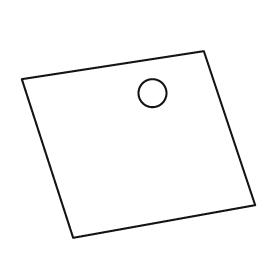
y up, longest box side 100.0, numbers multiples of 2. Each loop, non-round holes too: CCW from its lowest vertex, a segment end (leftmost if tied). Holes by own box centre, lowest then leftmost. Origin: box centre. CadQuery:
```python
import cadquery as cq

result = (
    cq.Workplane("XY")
    .moveTo(-28.0, -40.0)
    .lineTo(50.0, -26.0)
    .lineTo(28.0, 40.0)
    .lineTo(-50.0, 28.0)
    .close()
    .moveTo(6.0, 22.0)
    .circle(6.0)
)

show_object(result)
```